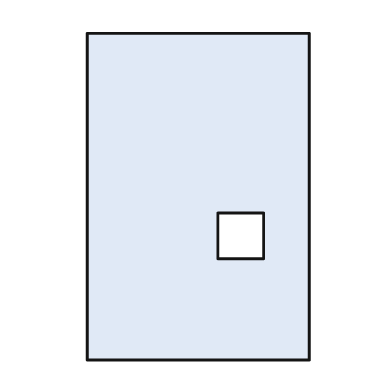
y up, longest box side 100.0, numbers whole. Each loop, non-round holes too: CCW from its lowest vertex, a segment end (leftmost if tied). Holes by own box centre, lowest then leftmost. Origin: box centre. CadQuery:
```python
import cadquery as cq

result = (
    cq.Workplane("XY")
    .moveTo(-34.0, -50.0)
    .lineTo(34.0, -50.0)
    .lineTo(34.0, 50.0)
    .lineTo(-34.0, 50.0)
    .close()
    .moveTo(6.0, -19.0)
    .lineTo(20.0, -19.0)
    .lineTo(20.0, -5.0)
    .lineTo(6.0, -5.0)
    .close()
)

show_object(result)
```